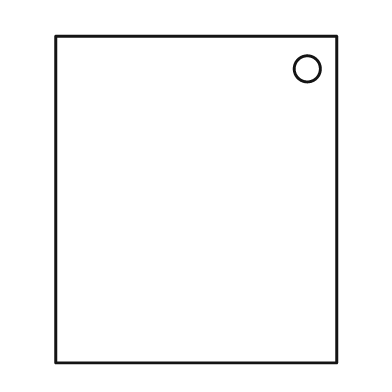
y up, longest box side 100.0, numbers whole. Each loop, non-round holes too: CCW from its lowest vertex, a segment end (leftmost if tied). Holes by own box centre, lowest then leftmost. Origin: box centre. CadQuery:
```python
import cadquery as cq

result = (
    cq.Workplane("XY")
    .moveTo(-43.0, -50.0)
    .lineTo(43.0, -50.0)
    .lineTo(43.0, 50.0)
    .lineTo(-43.0, 50.0)
    .close()
    .moveTo(34.0, 40.0)
    .circle(4.0)
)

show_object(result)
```